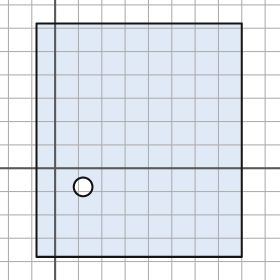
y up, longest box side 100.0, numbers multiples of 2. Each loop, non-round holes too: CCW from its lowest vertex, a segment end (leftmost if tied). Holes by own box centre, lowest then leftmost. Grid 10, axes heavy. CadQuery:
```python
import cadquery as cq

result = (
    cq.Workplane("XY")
    .moveTo(-8.0, -38.0)
    .lineTo(80.0, -38.0)
    .lineTo(80.0, 62.0)
    .lineTo(-8.0, 62.0)
    .close()
    .moveTo(12.0, -8.0)
    .circle(4.0)
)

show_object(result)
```